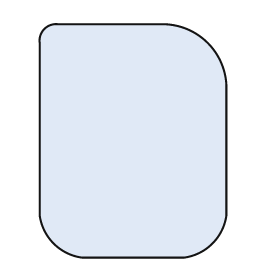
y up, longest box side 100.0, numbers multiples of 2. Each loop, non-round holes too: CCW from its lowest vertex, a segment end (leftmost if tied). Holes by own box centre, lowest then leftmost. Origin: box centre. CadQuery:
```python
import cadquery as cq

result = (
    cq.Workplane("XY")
    .moveTo(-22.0, -50.0)
    .lineTo(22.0, -50.0)
    .threePointArc((34.0, -44.0), (40.0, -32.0))
    .lineTo(40.0, 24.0)
    .threePointArc((32.0, 42.0), (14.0, 50.0))
    .lineTo(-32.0, 50.0)
    .threePointArc((-38.0, 48.0), (-40.0, 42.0))
    .lineTo(-40.0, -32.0)
    .threePointArc((-34.0, -44.0), (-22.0, -50.0))
    .close()
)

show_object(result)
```